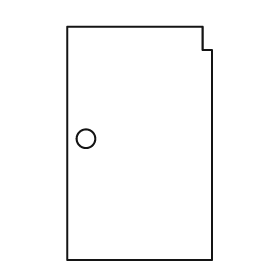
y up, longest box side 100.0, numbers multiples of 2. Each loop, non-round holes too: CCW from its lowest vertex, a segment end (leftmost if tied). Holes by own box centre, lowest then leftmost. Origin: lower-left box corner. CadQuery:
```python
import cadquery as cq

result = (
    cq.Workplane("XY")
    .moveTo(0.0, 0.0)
    .lineTo(62.0, 0.0)
    .lineTo(62.0, 90.0)
    .lineTo(58.0, 90.0)
    .lineTo(58.0, 100.0)
    .lineTo(0.0, 100.0)
    .close()
    .moveTo(8.0, 52.0)
    .circle(4.0)
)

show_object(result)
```